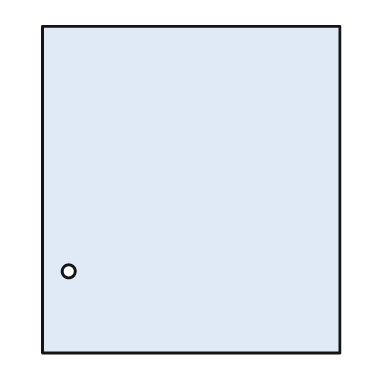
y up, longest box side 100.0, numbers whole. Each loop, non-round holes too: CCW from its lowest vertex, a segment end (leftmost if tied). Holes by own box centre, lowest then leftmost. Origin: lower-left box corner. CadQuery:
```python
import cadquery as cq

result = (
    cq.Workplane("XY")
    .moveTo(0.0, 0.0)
    .lineTo(91.0, 0.0)
    .lineTo(91.0, 100.0)
    .lineTo(0.0, 100.0)
    .close()
    .moveTo(8.0, 25.0)
    .circle(2.0)
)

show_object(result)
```